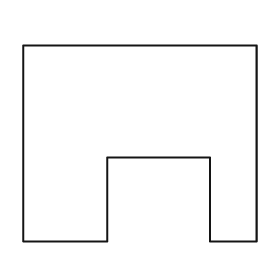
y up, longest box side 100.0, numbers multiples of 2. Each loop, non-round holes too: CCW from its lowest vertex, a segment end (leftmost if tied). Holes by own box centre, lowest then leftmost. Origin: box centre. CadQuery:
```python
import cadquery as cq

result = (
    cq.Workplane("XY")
    .moveTo(-50.0, -42.0)
    .lineTo(-14.0, -42.0)
    .lineTo(-14.0, -6.0)
    .lineTo(30.0, -6.0)
    .lineTo(30.0, -42.0)
    .lineTo(50.0, -42.0)
    .lineTo(50.0, 42.0)
    .lineTo(-50.0, 42.0)
    .close()
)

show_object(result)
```